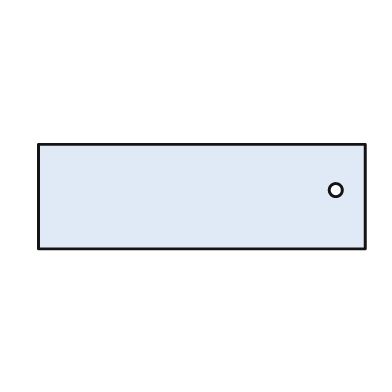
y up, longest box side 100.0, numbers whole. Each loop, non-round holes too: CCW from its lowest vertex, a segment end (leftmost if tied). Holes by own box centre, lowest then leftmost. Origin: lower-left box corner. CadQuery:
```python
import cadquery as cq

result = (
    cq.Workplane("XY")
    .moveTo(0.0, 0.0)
    .lineTo(100.0, 0.0)
    .lineTo(100.0, 32.0)
    .lineTo(0.0, 32.0)
    .close()
    .moveTo(91.0, 18.0)
    .circle(2.0)
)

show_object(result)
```